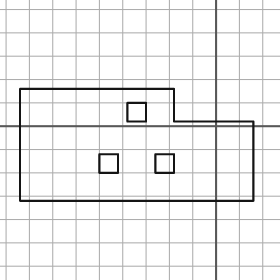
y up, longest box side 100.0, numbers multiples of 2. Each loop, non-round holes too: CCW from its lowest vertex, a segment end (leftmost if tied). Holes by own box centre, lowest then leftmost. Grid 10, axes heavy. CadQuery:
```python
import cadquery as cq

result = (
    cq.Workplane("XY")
    .moveTo(-84.0, -32.0)
    .lineTo(16.0, -32.0)
    .lineTo(16.0, 2.0)
    .lineTo(-18.0, 2.0)
    .lineTo(-18.0, 16.0)
    .lineTo(-84.0, 16.0)
    .close()
    .moveTo(-50.0, -20.0)
    .lineTo(-42.0, -20.0)
    .lineTo(-42.0, -12.0)
    .lineTo(-50.0, -12.0)
    .close()
    .moveTo(-26.0, -20.0)
    .lineTo(-18.0, -20.0)
    .lineTo(-18.0, -12.0)
    .lineTo(-26.0, -12.0)
    .close()
    .moveTo(-38.0, 2.0)
    .lineTo(-30.0, 2.0)
    .lineTo(-30.0, 10.0)
    .lineTo(-38.0, 10.0)
    .close()
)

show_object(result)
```